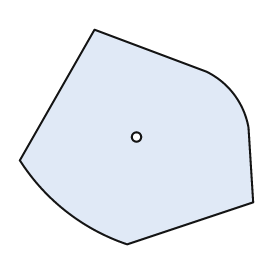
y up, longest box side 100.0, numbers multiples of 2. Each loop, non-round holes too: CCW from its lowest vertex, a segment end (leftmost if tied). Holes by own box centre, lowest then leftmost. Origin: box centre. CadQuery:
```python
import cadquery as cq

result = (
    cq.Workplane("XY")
    .moveTo(-4.0, -46.0)
    .lineTo(50.0, -28.0)
    .lineTo(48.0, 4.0)
    .threePointArc((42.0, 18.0), (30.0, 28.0))
    .lineTo(-18.0, 46.0)
    .lineTo(-50.0, -10.0)
    .threePointArc((-30.0, -32.0), (-4.0, -46.0))
    .close()
    .moveTo(0.0, 0.0)
    .circle(2.0)
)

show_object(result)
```